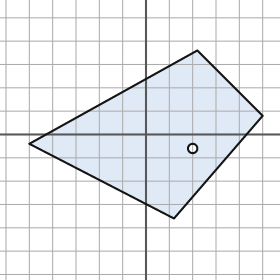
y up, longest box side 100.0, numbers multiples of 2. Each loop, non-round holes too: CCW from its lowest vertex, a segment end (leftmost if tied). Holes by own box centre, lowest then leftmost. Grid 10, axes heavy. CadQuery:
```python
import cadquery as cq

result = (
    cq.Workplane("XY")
    .moveTo(12.0, -36.0)
    .lineTo(50.0, 8.0)
    .lineTo(22.0, 36.0)
    .lineTo(-50.0, -4.0)
    .close()
    .moveTo(20.0, -6.0)
    .circle(2.0)
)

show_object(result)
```